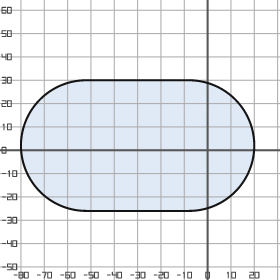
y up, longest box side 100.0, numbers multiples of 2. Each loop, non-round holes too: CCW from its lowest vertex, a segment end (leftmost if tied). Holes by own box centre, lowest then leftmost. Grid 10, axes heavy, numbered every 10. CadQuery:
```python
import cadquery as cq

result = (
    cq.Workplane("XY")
    .moveTo(-52.0, -26.0)
    .lineTo(-8.0, -26.0)
    .threePointArc((20.0, 2.0), (-8.0, 30.0))
    .lineTo(-52.0, 30.0)
    .threePointArc((-80.0, 2.0), (-52.0, -26.0))
    .close()
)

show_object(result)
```